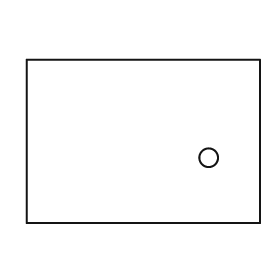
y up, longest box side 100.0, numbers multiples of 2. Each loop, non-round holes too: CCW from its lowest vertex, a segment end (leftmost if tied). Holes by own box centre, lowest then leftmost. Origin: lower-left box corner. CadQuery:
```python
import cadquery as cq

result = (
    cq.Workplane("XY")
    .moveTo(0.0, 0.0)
    .lineTo(100.0, 0.0)
    .lineTo(100.0, 70.0)
    .lineTo(0.0, 70.0)
    .close()
    .moveTo(78.0, 28.0)
    .circle(4.0)
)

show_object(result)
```